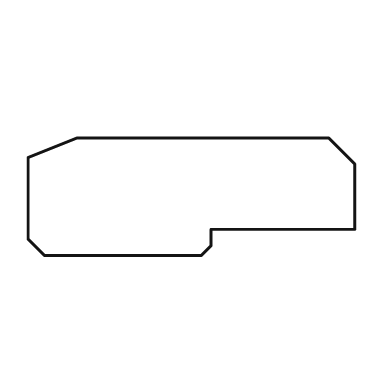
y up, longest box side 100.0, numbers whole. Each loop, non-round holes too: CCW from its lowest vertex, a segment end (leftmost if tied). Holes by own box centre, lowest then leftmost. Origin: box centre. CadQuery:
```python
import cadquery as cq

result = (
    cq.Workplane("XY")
    .moveTo(-45.0, -18.0)
    .lineTo(3.0, -18.0)
    .lineTo(6.0, -15.0)
    .lineTo(6.0, -10.0)
    .lineTo(50.0, -10.0)
    .lineTo(50.0, 10.0)
    .lineTo(42.0, 18.0)
    .lineTo(-35.0, 18.0)
    .lineTo(-50.0, 12.0)
    .lineTo(-50.0, -13.0)
    .close()
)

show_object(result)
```